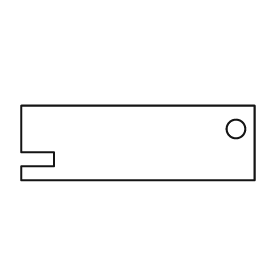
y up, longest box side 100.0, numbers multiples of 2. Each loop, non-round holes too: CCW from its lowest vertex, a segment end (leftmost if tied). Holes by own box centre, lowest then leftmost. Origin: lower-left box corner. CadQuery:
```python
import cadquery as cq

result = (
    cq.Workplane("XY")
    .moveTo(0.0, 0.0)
    .lineTo(100.0, 0.0)
    .lineTo(100.0, 32.0)
    .lineTo(0.0, 32.0)
    .lineTo(0.0, 12.0)
    .lineTo(14.0, 12.0)
    .lineTo(14.0, 6.0)
    .lineTo(0.0, 6.0)
    .close()
    .moveTo(92.0, 22.0)
    .circle(4.0)
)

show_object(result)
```